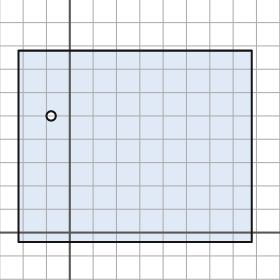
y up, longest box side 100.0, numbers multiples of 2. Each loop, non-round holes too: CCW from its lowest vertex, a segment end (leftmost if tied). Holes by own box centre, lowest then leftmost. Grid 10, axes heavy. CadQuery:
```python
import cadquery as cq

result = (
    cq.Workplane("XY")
    .moveTo(-22.0, -4.0)
    .lineTo(78.0, -4.0)
    .lineTo(78.0, 78.0)
    .lineTo(-22.0, 78.0)
    .close()
    .moveTo(-8.0, 50.0)
    .circle(2.0)
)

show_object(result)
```